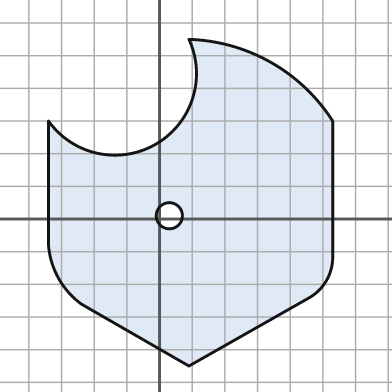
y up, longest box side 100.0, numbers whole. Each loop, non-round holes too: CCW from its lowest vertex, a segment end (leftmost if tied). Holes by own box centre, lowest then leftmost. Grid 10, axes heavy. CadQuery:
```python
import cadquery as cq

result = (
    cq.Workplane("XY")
    .moveTo(9.0, -45.0)
    .lineTo(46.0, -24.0)
    .threePointArc((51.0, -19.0), (53.0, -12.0))
    .lineTo(53.0, 30.0)
    .threePointArc((34.0, 48.0), (9.0, 55.0))
    .threePointArc((-1.0, 23.0), (-34.0, 30.0))
    .lineTo(-34.0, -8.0)
    .threePointArc((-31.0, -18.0), (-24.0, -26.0))
    .close()
    .moveTo(3.0, 1.0)
    .circle(4.0)
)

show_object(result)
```